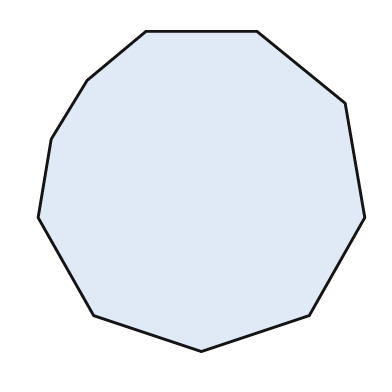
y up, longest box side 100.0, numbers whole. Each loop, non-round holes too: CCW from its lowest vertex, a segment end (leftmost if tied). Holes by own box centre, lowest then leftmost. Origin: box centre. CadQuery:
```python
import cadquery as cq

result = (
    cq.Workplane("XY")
    .moveTo(0.0, -49.0)
    .lineTo(33.0, -38.0)
    .lineTo(50.0, -8.0)
    .lineTo(44.0, 27.0)
    .lineTo(17.0, 49.0)
    .lineTo(-17.0, 49.0)
    .lineTo(-35.0, 34.0)
    .lineTo(-46.0, 16.0)
    .lineTo(-50.0, -8.0)
    .lineTo(-33.0, -38.0)
    .close()
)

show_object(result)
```